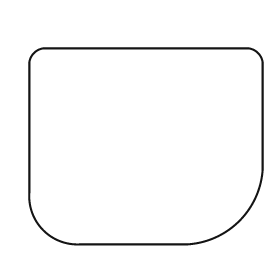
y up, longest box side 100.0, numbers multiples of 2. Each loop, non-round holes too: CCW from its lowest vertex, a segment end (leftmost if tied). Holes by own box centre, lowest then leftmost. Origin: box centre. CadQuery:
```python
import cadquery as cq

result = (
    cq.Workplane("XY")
    .moveTo(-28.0, -42.0)
    .lineTo(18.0, -42.0)
    .threePointArc((40.0, -32.0), (50.0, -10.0))
    .lineTo(50.0, 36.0)
    .threePointArc((48.0, 40.0), (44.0, 42.0))
    .lineTo(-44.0, 42.0)
    .threePointArc((-48.0, 40.0), (-50.0, 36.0))
    .lineTo(-50.0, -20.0)
    .threePointArc((-44.0, -36.0), (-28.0, -42.0))
    .close()
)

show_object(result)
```